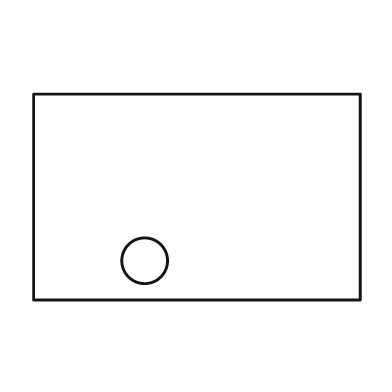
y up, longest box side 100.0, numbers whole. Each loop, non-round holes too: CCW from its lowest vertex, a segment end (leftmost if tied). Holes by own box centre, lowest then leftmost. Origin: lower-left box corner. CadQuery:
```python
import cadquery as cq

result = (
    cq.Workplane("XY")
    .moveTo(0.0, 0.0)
    .lineTo(100.0, 0.0)
    .lineTo(100.0, 63.0)
    .lineTo(0.0, 63.0)
    .close()
    .moveTo(34.0, 12.0)
    .circle(7.0)
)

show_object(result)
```